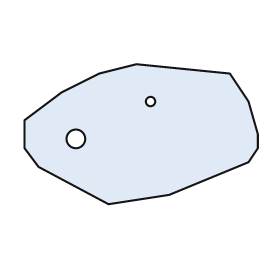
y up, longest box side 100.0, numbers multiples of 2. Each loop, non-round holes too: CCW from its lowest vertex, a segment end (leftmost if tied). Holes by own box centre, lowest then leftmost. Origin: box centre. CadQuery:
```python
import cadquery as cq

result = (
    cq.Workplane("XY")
    .moveTo(-14.0, -30.0)
    .lineTo(12.0, -26.0)
    .lineTo(46.0, -12.0)
    .lineTo(50.0, -6.0)
    .lineTo(50.0, 0.0)
    .lineTo(46.0, 14.0)
    .lineTo(38.0, 26.0)
    .lineTo(-2.0, 30.0)
    .lineTo(-18.0, 26.0)
    .lineTo(-34.0, 18.0)
    .lineTo(-50.0, 6.0)
    .lineTo(-50.0, -6.0)
    .lineTo(-44.0, -14.0)
    .close()
    .moveTo(-28.0, -2.0)
    .circle(4.0)
    .moveTo(4.0, 14.0)
    .circle(2.0)
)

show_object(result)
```